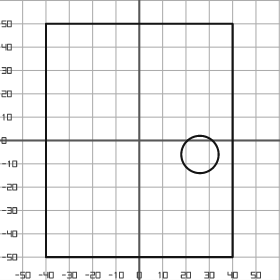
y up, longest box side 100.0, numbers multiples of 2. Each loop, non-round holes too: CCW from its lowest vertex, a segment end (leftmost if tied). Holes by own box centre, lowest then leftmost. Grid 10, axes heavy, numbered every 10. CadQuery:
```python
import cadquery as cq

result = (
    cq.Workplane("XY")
    .moveTo(-40.0, -50.0)
    .lineTo(40.0, -50.0)
    .lineTo(40.0, 50.0)
    .lineTo(-40.0, 50.0)
    .close()
    .moveTo(26.0, -6.0)
    .circle(8.0)
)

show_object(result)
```